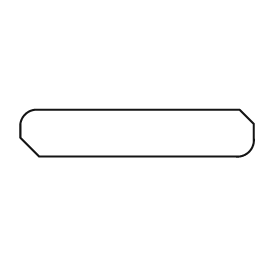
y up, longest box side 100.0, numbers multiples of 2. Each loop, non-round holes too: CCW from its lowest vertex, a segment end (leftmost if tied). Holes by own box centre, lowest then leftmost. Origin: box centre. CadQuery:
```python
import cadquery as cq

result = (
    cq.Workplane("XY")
    .moveTo(-42.0, -10.0)
    .lineTo(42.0, -10.0)
    .threePointArc((48.0, -8.0), (50.0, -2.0))
    .lineTo(50.0, 4.0)
    .lineTo(44.0, 10.0)
    .lineTo(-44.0, 10.0)
    .threePointArc((-48.0, 8.0), (-50.0, 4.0))
    .lineTo(-50.0, -2.0)
    .close()
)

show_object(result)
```